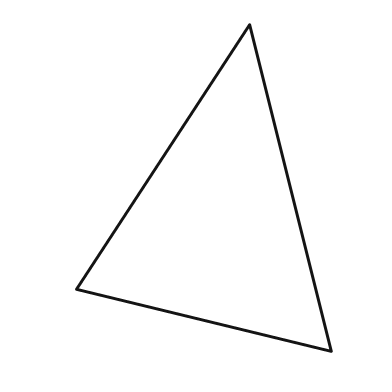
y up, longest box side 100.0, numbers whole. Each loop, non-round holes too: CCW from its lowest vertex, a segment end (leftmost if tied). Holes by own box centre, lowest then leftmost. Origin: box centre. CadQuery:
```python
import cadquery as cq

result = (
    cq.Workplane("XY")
    .moveTo(39.0, -50.0)
    .lineTo(14.0, 50.0)
    .lineTo(-39.0, -31.0)
    .close()
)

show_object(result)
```